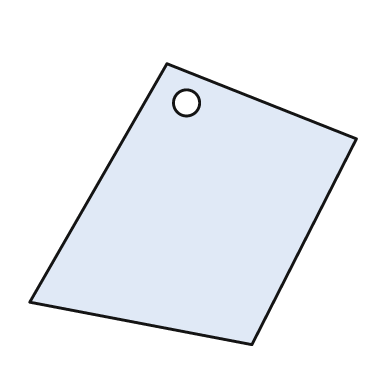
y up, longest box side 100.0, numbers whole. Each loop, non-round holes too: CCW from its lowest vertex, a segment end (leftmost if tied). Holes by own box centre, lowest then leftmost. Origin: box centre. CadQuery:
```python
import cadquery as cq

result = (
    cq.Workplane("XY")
    .moveTo(18.0, -43.0)
    .lineTo(50.0, 20.0)
    .lineTo(-8.0, 43.0)
    .lineTo(-50.0, -30.0)
    .close()
    .moveTo(-2.0, 31.0)
    .circle(4.0)
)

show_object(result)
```